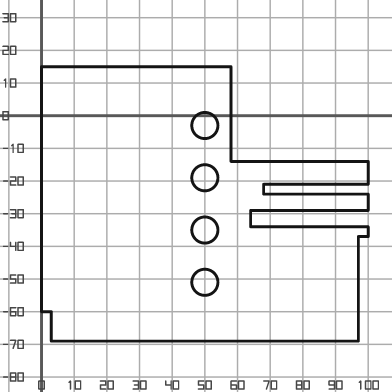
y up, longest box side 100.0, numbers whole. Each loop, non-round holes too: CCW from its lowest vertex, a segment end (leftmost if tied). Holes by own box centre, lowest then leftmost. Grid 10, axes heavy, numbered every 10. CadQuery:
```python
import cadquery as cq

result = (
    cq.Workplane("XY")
    .moveTo(3.0, -69.0)
    .lineTo(97.0, -69.0)
    .lineTo(97.0, -37.0)
    .lineTo(100.0, -37.0)
    .lineTo(100.0, -34.0)
    .lineTo(64.0, -34.0)
    .lineTo(64.0, -29.0)
    .lineTo(100.0, -29.0)
    .lineTo(100.0, -24.0)
    .lineTo(68.0, -24.0)
    .lineTo(68.0, -21.0)
    .lineTo(100.0, -21.0)
    .lineTo(100.0, -14.0)
    .lineTo(58.0, -14.0)
    .lineTo(58.0, 15.0)
    .lineTo(0.0, 15.0)
    .lineTo(0.0, -60.0)
    .lineTo(3.0, -60.0)
    .close()
    .moveTo(50.0, -51.0)
    .circle(4.0)
    .moveTo(50.0, -35.0)
    .circle(4.0)
    .moveTo(50.0, -19.0)
    .circle(4.0)
    .moveTo(50.0, -3.0)
    .circle(4.0)
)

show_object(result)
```